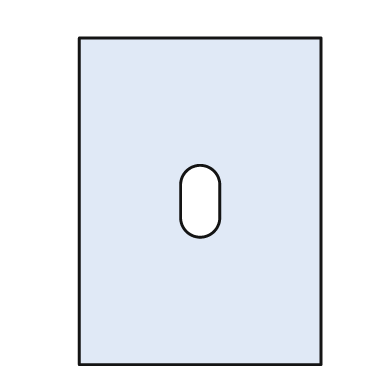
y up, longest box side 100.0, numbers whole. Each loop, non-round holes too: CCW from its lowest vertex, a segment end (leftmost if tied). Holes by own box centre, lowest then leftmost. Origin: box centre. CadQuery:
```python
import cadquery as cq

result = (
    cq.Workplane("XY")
    .moveTo(-37.0, -50.0)
    .lineTo(37.0, -50.0)
    .lineTo(37.0, 50.0)
    .lineTo(-37.0, 50.0)
    .close()
    .moveTo(-6.0, -5.0)
    .threePointArc((0.0, -11.0), (6.0, -5.0))
    .lineTo(6.0, 5.0)
    .threePointArc((0.0, 11.0), (-6.0, 5.0))
    .close()
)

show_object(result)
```